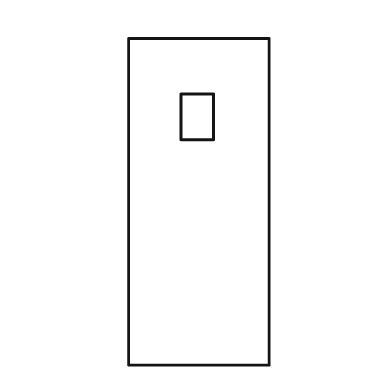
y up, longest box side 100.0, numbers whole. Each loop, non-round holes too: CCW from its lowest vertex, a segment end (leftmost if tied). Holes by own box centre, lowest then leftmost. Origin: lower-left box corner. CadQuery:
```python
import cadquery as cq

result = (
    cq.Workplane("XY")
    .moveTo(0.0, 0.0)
    .lineTo(43.0, 0.0)
    .lineTo(43.0, 100.0)
    .lineTo(0.0, 100.0)
    .close()
    .moveTo(16.0, 69.0)
    .lineTo(26.0, 69.0)
    .lineTo(26.0, 83.0)
    .lineTo(16.0, 83.0)
    .close()
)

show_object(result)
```